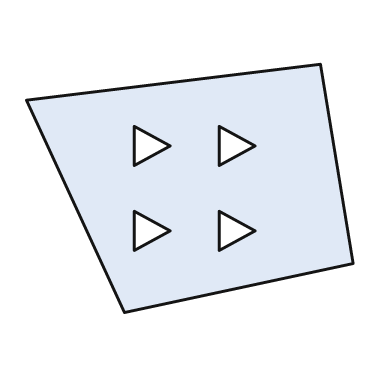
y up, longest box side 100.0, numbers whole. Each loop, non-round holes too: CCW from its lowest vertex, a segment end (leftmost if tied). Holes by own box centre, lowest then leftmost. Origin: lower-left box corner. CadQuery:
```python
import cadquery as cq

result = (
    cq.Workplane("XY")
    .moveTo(30.0, 0.0)
    .lineTo(100.0, 15.0)
    .lineTo(90.0, 76.0)
    .lineTo(0.0, 65.0)
    .close()
    .moveTo(33.0, 19.0)
    .lineTo(44.0, 25.0)
    .lineTo(33.0, 31.0)
    .close()
    .moveTo(59.0, 19.0)
    .lineTo(70.0, 25.0)
    .lineTo(59.0, 31.0)
    .close()
    .moveTo(33.0, 45.0)
    .lineTo(44.0, 51.0)
    .lineTo(33.0, 57.0)
    .close()
    .moveTo(59.0, 45.0)
    .lineTo(70.0, 51.0)
    .lineTo(59.0, 57.0)
    .close()
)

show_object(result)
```